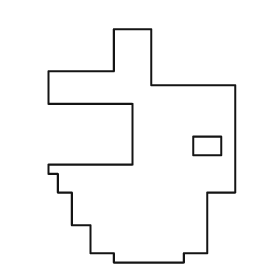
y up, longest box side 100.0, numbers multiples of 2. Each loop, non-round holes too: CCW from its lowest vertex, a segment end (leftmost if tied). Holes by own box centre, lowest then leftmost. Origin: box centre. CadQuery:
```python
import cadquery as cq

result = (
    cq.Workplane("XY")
    .moveTo(-12.0, -50.0)
    .lineTo(18.0, -50.0)
    .lineTo(18.0, -46.0)
    .lineTo(28.0, -46.0)
    .lineTo(28.0, -20.0)
    .lineTo(40.0, -20.0)
    .lineTo(40.0, 26.0)
    .lineTo(4.0, 26.0)
    .lineTo(4.0, 50.0)
    .lineTo(-12.0, 50.0)
    .lineTo(-12.0, 32.0)
    .lineTo(-40.0, 32.0)
    .lineTo(-40.0, 18.0)
    .lineTo(-4.0, 18.0)
    .lineTo(-4.0, -8.0)
    .lineTo(-40.0, -8.0)
    .lineTo(-40.0, -12.0)
    .lineTo(-36.0, -12.0)
    .lineTo(-36.0, -20.0)
    .lineTo(-30.0, -20.0)
    .lineTo(-30.0, -34.0)
    .lineTo(-22.0, -34.0)
    .lineTo(-22.0, -46.0)
    .lineTo(-12.0, -46.0)
    .close()
    .moveTo(22.0, -4.0)
    .lineTo(34.0, -4.0)
    .lineTo(34.0, 4.0)
    .lineTo(22.0, 4.0)
    .close()
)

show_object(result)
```